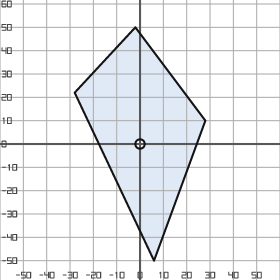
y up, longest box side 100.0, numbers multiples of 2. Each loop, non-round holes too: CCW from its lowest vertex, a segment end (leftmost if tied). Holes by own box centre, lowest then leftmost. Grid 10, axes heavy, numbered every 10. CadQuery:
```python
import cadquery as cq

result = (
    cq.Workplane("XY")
    .moveTo(6.0, -50.0)
    .lineTo(28.0, 10.0)
    .lineTo(-2.0, 50.0)
    .lineTo(-28.0, 22.0)
    .close()
    .moveTo(0.0, 0.0)
    .circle(2.0)
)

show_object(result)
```